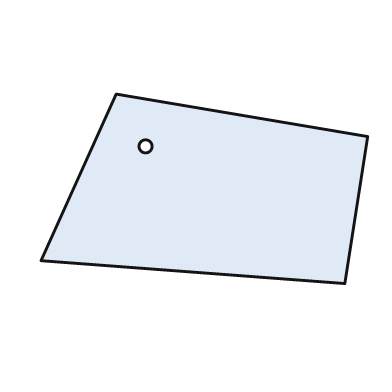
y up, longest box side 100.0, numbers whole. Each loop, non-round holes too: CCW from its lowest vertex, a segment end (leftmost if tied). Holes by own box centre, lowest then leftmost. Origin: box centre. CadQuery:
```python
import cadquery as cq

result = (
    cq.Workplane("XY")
    .moveTo(43.0, -29.0)
    .lineTo(50.0, 16.0)
    .lineTo(-27.0, 29.0)
    .lineTo(-50.0, -22.0)
    .close()
    .moveTo(-18.0, 13.0)
    .circle(2.0)
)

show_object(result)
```